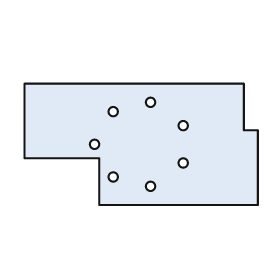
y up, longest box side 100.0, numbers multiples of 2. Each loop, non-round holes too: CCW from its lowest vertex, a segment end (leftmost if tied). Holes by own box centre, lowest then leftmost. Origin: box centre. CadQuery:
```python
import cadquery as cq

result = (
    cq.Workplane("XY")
    .moveTo(-18.0, -26.0)
    .lineTo(50.0, -26.0)
    .lineTo(50.0, 6.0)
    .lineTo(44.0, 6.0)
    .lineTo(44.0, 26.0)
    .lineTo(-50.0, 26.0)
    .lineTo(-50.0, -6.0)
    .lineTo(-18.0, -6.0)
    .close()
    .moveTo(4.0, -18.0)
    .circle(2.0)
    .moveTo(-12.0, -14.0)
    .circle(2.0)
    .moveTo(18.0, -8.0)
    .circle(2.0)
    .moveTo(-20.0, 0.0)
    .circle(2.0)
    .moveTo(18.0, 8.0)
    .circle(2.0)
    .moveTo(-12.0, 14.0)
    .circle(2.0)
    .moveTo(4.0, 18.0)
    .circle(2.0)
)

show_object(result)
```